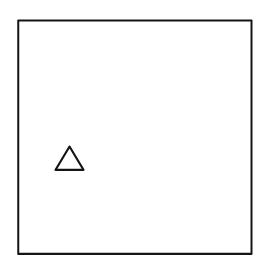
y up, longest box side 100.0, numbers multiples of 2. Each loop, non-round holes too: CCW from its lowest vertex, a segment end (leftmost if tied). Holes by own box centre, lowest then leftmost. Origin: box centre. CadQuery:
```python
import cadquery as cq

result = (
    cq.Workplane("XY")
    .moveTo(-50.0, -50.0)
    .lineTo(50.0, -50.0)
    .lineTo(50.0, 50.0)
    .lineTo(-50.0, 50.0)
    .close()
    .moveTo(-34.0, -14.0)
    .lineTo(-22.0, -14.0)
    .lineTo(-28.0, -4.0)
    .close()
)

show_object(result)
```